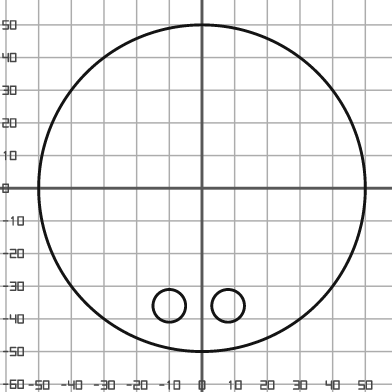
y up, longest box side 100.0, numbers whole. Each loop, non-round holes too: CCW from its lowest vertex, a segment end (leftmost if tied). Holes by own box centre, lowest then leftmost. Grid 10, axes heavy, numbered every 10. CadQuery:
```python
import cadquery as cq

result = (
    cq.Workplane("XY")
    .moveTo(0.0, 0.0)
    .circle(50.0)
    .moveTo(-10.0, -36.0)
    .circle(5.0)
    .moveTo(8.0, -36.0)
    .circle(5.0)
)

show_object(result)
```